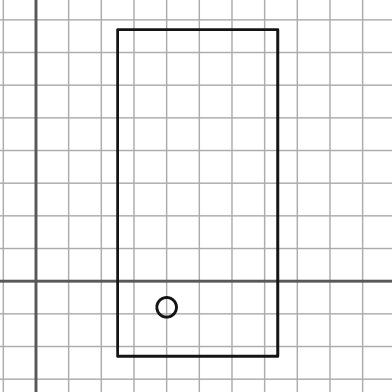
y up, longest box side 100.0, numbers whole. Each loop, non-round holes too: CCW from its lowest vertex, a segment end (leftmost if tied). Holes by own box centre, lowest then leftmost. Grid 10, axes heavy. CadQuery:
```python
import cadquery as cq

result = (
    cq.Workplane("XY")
    .moveTo(25.0, -23.0)
    .lineTo(74.0, -23.0)
    .lineTo(74.0, 77.0)
    .lineTo(25.0, 77.0)
    .close()
    .moveTo(40.0, -8.0)
    .circle(3.0)
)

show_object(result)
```